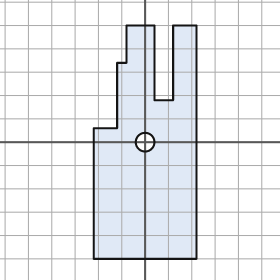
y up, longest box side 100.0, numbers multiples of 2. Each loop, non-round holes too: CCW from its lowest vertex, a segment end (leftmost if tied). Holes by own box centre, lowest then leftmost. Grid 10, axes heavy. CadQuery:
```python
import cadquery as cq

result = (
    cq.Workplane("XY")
    .moveTo(-22.0, -50.0)
    .lineTo(22.0, -50.0)
    .lineTo(22.0, 50.0)
    .lineTo(12.0, 50.0)
    .lineTo(12.0, 18.0)
    .lineTo(4.0, 18.0)
    .lineTo(4.0, 50.0)
    .lineTo(-8.0, 50.0)
    .lineTo(-8.0, 34.0)
    .lineTo(-12.0, 34.0)
    .lineTo(-12.0, 6.0)
    .lineTo(-22.0, 6.0)
    .close()
    .moveTo(0.0, 0.0)
    .circle(4.0)
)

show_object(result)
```